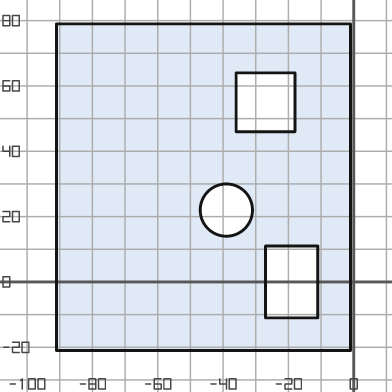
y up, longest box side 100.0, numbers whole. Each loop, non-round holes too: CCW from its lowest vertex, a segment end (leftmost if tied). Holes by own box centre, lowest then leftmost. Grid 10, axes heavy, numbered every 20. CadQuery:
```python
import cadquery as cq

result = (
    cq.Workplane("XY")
    .moveTo(-91.0, -21.0)
    .lineTo(-1.0, -21.0)
    .lineTo(-1.0, 79.0)
    .lineTo(-91.0, 79.0)
    .close()
    .moveTo(-27.0, -11.0)
    .lineTo(-11.0, -11.0)
    .lineTo(-11.0, 11.0)
    .lineTo(-27.0, 11.0)
    .close()
    .moveTo(-39.0, 22.0)
    .circle(8.0)
    .moveTo(-36.0, 46.0)
    .lineTo(-18.0, 46.0)
    .lineTo(-18.0, 64.0)
    .lineTo(-36.0, 64.0)
    .close()
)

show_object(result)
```